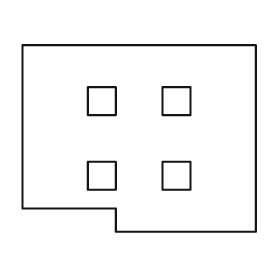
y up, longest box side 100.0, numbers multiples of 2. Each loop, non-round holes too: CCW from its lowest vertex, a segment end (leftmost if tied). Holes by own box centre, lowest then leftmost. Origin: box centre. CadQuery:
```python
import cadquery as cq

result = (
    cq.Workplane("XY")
    .moveTo(-10.0, -40.0)
    .lineTo(50.0, -40.0)
    .lineTo(50.0, 40.0)
    .lineTo(-50.0, 40.0)
    .lineTo(-50.0, -30.0)
    .lineTo(-10.0, -30.0)
    .close()
    .moveTo(-22.0, -22.0)
    .lineTo(-10.0, -22.0)
    .lineTo(-10.0, -10.0)
    .lineTo(-22.0, -10.0)
    .close()
    .moveTo(10.0, -22.0)
    .lineTo(22.0, -22.0)
    .lineTo(22.0, -10.0)
    .lineTo(10.0, -10.0)
    .close()
    .moveTo(-22.0, 10.0)
    .lineTo(-10.0, 10.0)
    .lineTo(-10.0, 22.0)
    .lineTo(-22.0, 22.0)
    .close()
    .moveTo(10.0, 10.0)
    .lineTo(22.0, 10.0)
    .lineTo(22.0, 22.0)
    .lineTo(10.0, 22.0)
    .close()
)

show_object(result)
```